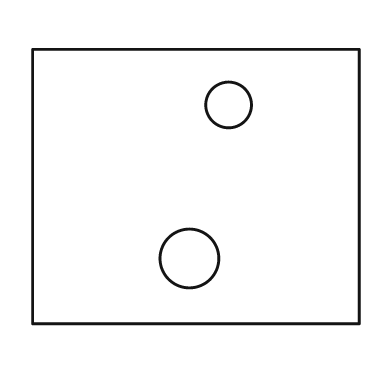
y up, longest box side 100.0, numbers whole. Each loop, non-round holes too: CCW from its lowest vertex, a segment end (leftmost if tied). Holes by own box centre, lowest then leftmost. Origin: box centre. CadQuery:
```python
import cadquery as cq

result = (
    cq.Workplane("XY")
    .moveTo(-50.0, -42.0)
    .lineTo(50.0, -42.0)
    .lineTo(50.0, 42.0)
    .lineTo(-50.0, 42.0)
    .close()
    .moveTo(-2.0, -22.0)
    .circle(9.0)
    .moveTo(10.0, 25.0)
    .circle(7.0)
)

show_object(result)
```